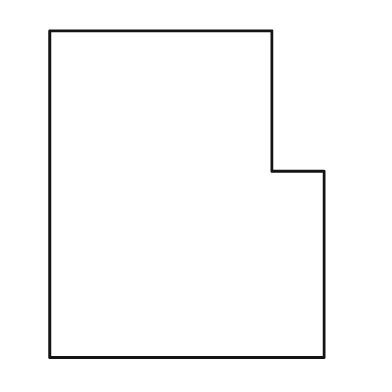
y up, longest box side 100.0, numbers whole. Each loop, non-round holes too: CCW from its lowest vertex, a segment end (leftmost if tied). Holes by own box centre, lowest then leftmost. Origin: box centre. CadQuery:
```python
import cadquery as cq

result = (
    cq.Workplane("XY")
    .moveTo(-42.0, -50.0)
    .lineTo(42.0, -50.0)
    .lineTo(42.0, 7.0)
    .lineTo(26.0, 7.0)
    .lineTo(26.0, 50.0)
    .lineTo(-42.0, 50.0)
    .close()
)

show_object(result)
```